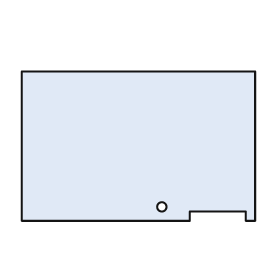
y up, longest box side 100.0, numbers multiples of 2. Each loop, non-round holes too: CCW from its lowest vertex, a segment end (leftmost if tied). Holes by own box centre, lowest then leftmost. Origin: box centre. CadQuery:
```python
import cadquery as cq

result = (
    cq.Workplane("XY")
    .moveTo(-50.0, -32.0)
    .lineTo(22.0, -32.0)
    .lineTo(22.0, -28.0)
    .lineTo(46.0, -28.0)
    .lineTo(46.0, -32.0)
    .lineTo(50.0, -32.0)
    .lineTo(50.0, 32.0)
    .lineTo(-50.0, 32.0)
    .close()
    .moveTo(10.0, -26.0)
    .circle(2.0)
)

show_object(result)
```